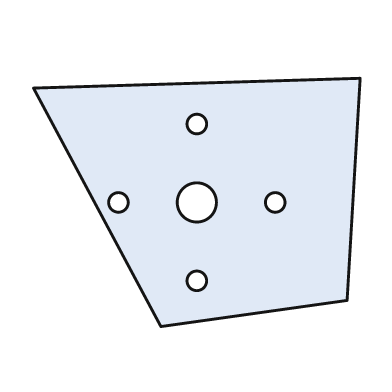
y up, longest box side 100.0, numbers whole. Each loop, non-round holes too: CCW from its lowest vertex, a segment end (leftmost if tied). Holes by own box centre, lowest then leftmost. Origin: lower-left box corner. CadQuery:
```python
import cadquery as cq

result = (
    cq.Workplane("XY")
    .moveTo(39.0, 0.0)
    .lineTo(96.0, 8.0)
    .lineTo(100.0, 76.0)
    .lineTo(0.0, 73.0)
    .close()
    .moveTo(50.0, 14.0)
    .circle(3.0)
    .moveTo(26.0, 38.0)
    .circle(3.0)
    .moveTo(50.0, 38.0)
    .circle(6.0)
    .moveTo(74.0, 38.0)
    .circle(3.0)
    .moveTo(50.0, 62.0)
    .circle(3.0)
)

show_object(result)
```